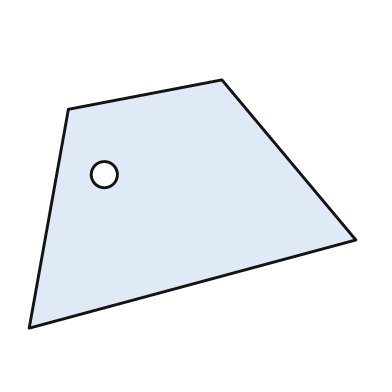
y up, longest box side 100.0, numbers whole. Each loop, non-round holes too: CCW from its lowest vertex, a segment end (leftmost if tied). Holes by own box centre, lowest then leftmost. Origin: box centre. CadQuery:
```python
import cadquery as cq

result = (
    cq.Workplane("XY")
    .moveTo(-50.0, -38.0)
    .lineTo(50.0, -11.0)
    .lineTo(9.0, 38.0)
    .lineTo(-38.0, 29.0)
    .close()
    .moveTo(-27.0, 9.0)
    .circle(4.0)
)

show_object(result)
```